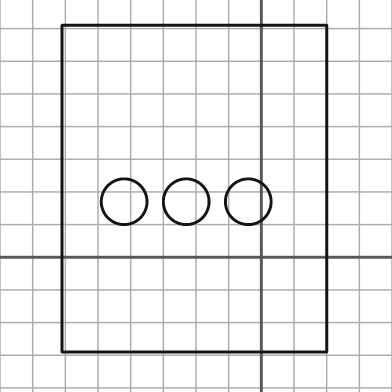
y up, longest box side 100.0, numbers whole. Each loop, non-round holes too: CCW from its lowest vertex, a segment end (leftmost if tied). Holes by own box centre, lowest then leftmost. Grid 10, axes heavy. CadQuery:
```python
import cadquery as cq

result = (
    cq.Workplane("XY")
    .moveTo(-61.0, -29.0)
    .lineTo(20.0, -29.0)
    .lineTo(20.0, 71.0)
    .lineTo(-61.0, 71.0)
    .close()
    .moveTo(-42.0, 17.0)
    .circle(7.0)
    .moveTo(-23.0, 17.0)
    .circle(7.0)
    .moveTo(-4.0, 17.0)
    .circle(7.0)
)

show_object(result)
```